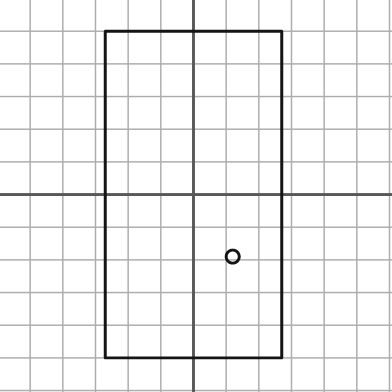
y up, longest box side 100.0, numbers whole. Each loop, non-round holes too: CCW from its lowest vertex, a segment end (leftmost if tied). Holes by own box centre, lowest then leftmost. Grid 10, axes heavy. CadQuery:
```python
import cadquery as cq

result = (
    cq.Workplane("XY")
    .moveTo(-27.0, -50.0)
    .lineTo(27.0, -50.0)
    .lineTo(27.0, 50.0)
    .lineTo(-27.0, 50.0)
    .close()
    .moveTo(12.0, -19.0)
    .circle(2.0)
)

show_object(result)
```